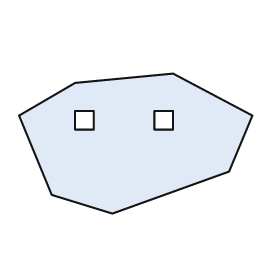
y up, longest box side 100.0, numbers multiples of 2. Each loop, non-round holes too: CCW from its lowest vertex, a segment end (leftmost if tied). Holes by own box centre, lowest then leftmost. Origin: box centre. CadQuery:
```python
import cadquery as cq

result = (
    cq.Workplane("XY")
    .moveTo(-10.0, -30.0)
    .lineTo(40.0, -12.0)
    .lineTo(50.0, 12.0)
    .lineTo(16.0, 30.0)
    .lineTo(-26.0, 26.0)
    .lineTo(-50.0, 12.0)
    .lineTo(-36.0, -22.0)
    .close()
    .moveTo(-26.0, 6.0)
    .lineTo(-18.0, 6.0)
    .lineTo(-18.0, 14.0)
    .lineTo(-26.0, 14.0)
    .close()
    .moveTo(8.0, 6.0)
    .lineTo(16.0, 6.0)
    .lineTo(16.0, 14.0)
    .lineTo(8.0, 14.0)
    .close()
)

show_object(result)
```